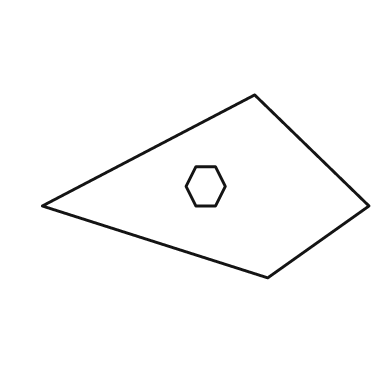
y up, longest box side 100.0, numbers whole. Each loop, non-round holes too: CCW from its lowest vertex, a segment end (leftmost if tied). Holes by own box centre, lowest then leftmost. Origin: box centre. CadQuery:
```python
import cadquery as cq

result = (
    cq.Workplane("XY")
    .moveTo(19.0, -28.0)
    .lineTo(50.0, -6.0)
    .lineTo(15.0, 28.0)
    .lineTo(-50.0, -6.0)
    .close()
    .moveTo(-3.0, -6.0)
    .lineTo(3.0, -6.0)
    .lineTo(6.0, 0.0)
    .lineTo(3.0, 6.0)
    .lineTo(-3.0, 6.0)
    .lineTo(-6.0, 0.0)
    .close()
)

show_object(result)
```